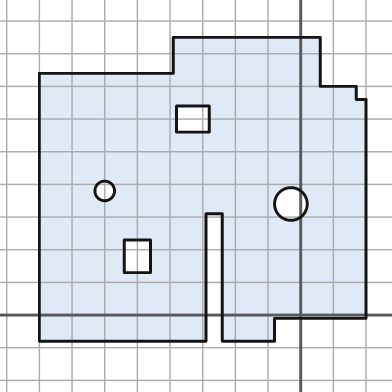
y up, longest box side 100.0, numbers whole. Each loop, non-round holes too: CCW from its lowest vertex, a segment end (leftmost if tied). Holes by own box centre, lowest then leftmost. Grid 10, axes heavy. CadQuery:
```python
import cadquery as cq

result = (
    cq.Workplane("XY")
    .moveTo(-80.0, -8.0)
    .lineTo(-29.0, -8.0)
    .lineTo(-29.0, 31.0)
    .lineTo(-24.0, 31.0)
    .lineTo(-24.0, -8.0)
    .lineTo(-8.0, -8.0)
    .lineTo(-8.0, -1.0)
    .lineTo(20.0, -1.0)
    .lineTo(20.0, 66.0)
    .lineTo(17.0, 66.0)
    .lineTo(17.0, 70.0)
    .lineTo(6.0, 70.0)
    .lineTo(6.0, 85.0)
    .lineTo(-39.0, 85.0)
    .lineTo(-39.0, 74.0)
    .lineTo(-80.0, 74.0)
    .close()
    .moveTo(-54.0, 13.0)
    .lineTo(-46.0, 13.0)
    .lineTo(-46.0, 23.0)
    .lineTo(-54.0, 23.0)
    .close()
    .moveTo(-3.0, 34.0)
    .circle(5.0)
    .moveTo(-60.0, 38.0)
    .circle(3.0)
    .moveTo(-38.0, 56.0)
    .lineTo(-28.0, 56.0)
    .lineTo(-28.0, 64.0)
    .lineTo(-38.0, 64.0)
    .close()
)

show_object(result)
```